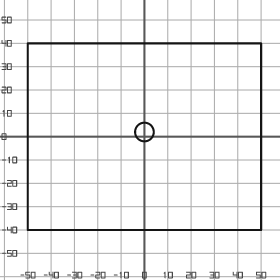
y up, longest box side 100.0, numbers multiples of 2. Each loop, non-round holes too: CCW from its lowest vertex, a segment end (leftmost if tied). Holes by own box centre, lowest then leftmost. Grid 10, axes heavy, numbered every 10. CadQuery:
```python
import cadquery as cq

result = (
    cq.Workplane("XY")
    .moveTo(-50.0, -40.0)
    .lineTo(50.0, -40.0)
    .lineTo(50.0, 40.0)
    .lineTo(-50.0, 40.0)
    .close()
    .moveTo(0.0, 2.0)
    .circle(4.0)
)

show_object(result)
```